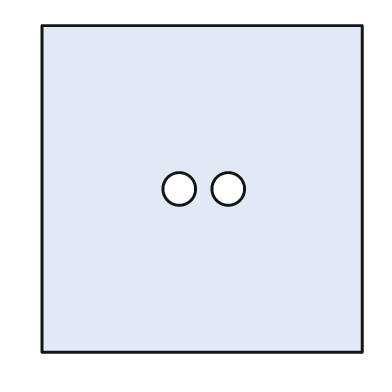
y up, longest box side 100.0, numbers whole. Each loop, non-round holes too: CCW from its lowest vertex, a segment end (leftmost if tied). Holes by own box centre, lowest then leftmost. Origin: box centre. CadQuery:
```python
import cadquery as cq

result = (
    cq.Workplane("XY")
    .moveTo(-49.0, -50.0)
    .lineTo(49.0, -50.0)
    .lineTo(49.0, 50.0)
    .lineTo(-49.0, 50.0)
    .close()
    .moveTo(-7.0, 0.0)
    .circle(5.0)
    .moveTo(8.0, 0.0)
    .circle(5.0)
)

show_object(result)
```